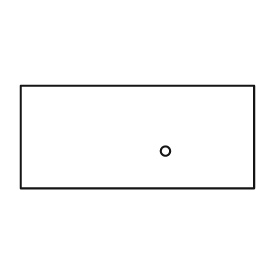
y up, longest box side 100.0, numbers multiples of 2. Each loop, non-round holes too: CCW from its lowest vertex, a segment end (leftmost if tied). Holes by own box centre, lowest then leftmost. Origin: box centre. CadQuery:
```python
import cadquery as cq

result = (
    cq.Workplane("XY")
    .moveTo(-50.0, -22.0)
    .lineTo(50.0, -22.0)
    .lineTo(50.0, 22.0)
    .lineTo(-50.0, 22.0)
    .close()
    .moveTo(12.0, -6.0)
    .circle(2.0)
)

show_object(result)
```